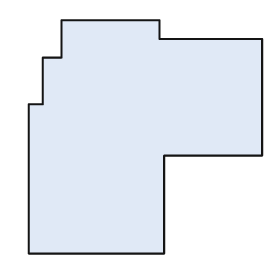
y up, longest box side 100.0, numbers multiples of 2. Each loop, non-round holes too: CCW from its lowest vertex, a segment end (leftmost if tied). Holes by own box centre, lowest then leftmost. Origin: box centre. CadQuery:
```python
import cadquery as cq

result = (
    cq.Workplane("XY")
    .moveTo(-50.0, -50.0)
    .lineTo(8.0, -50.0)
    .lineTo(8.0, -8.0)
    .lineTo(50.0, -8.0)
    .lineTo(50.0, 42.0)
    .lineTo(6.0, 42.0)
    .lineTo(6.0, 50.0)
    .lineTo(-36.0, 50.0)
    .lineTo(-36.0, 34.0)
    .lineTo(-44.0, 34.0)
    .lineTo(-44.0, 14.0)
    .lineTo(-50.0, 14.0)
    .close()
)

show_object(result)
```